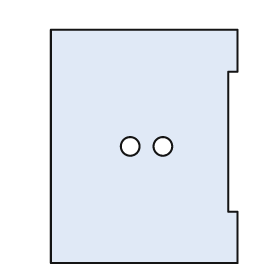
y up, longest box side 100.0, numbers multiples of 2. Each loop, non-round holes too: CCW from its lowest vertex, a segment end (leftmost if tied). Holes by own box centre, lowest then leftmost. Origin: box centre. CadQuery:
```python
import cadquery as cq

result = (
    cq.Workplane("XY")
    .moveTo(-40.0, -50.0)
    .lineTo(40.0, -50.0)
    .lineTo(40.0, -28.0)
    .lineTo(36.0, -28.0)
    .lineTo(36.0, 32.0)
    .lineTo(40.0, 32.0)
    .lineTo(40.0, 50.0)
    .lineTo(-40.0, 50.0)
    .close()
    .moveTo(-6.0, 0.0)
    .circle(4.0)
    .moveTo(8.0, 0.0)
    .circle(4.0)
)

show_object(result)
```